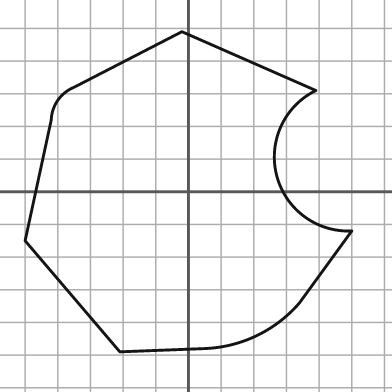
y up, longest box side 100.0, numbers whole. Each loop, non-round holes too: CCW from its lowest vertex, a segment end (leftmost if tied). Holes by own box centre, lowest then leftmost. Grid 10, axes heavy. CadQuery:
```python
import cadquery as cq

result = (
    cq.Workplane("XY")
    .moveTo(-21.0, -49.0)
    .lineTo(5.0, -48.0)
    .threePointArc((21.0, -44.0), (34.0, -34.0))
    .lineTo(50.0, -12.0)
    .threePointArc((27.0, 5.0), (39.0, 31.0))
    .lineTo(-2.0, 49.0)
    .lineTo(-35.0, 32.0)
    .threePointArc((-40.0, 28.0), (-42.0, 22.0))
    .lineTo(-50.0, -15.0)
    .close()
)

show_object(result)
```